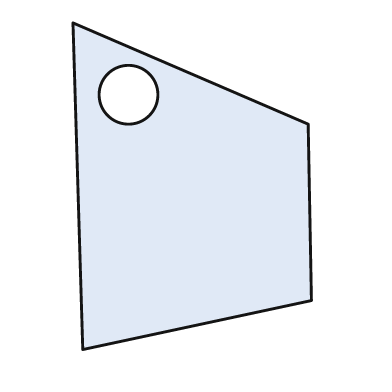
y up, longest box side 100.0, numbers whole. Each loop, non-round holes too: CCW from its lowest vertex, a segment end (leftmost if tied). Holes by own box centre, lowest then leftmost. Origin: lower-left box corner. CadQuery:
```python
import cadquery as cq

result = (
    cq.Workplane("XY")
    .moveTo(3.0, 0.0)
    .lineTo(73.0, 15.0)
    .lineTo(72.0, 69.0)
    .lineTo(0.0, 100.0)
    .close()
    .moveTo(17.0, 78.0)
    .circle(9.0)
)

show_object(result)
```